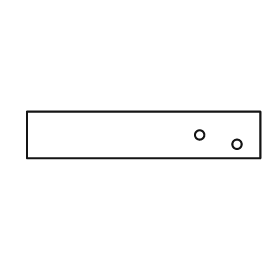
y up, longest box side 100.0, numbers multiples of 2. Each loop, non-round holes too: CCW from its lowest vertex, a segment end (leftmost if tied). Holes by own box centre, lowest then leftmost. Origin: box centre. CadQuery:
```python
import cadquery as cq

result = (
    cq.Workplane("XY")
    .moveTo(-50.0, -10.0)
    .lineTo(50.0, -10.0)
    .lineTo(50.0, 10.0)
    .lineTo(-50.0, 10.0)
    .close()
    .moveTo(40.0, -4.0)
    .circle(2.0)
    .moveTo(24.0, 0.0)
    .circle(2.0)
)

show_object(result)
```